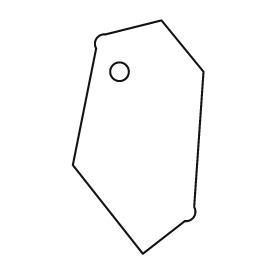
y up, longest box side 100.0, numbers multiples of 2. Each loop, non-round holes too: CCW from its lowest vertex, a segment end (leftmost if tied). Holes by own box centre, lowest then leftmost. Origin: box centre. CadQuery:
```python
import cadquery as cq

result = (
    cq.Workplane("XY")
    .moveTo(2.0, -50.0)
    .lineTo(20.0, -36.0)
    .threePointArc((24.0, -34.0), (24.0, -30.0))
    .lineTo(28.0, 28.0)
    .lineTo(10.0, 50.0)
    .lineTo(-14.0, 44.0)
    .threePointArc((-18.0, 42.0), (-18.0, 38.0))
    .lineTo(-28.0, -12.0)
    .close()
    .moveTo(-8.0, 28.0)
    .circle(4.0)
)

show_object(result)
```